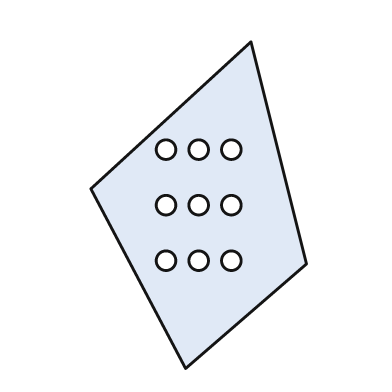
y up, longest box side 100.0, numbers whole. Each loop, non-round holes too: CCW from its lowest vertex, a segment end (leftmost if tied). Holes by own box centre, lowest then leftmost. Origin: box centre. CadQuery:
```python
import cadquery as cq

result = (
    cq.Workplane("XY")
    .moveTo(-4.0, -50.0)
    .lineTo(33.0, -18.0)
    .lineTo(16.0, 50.0)
    .lineTo(-33.0, 5.0)
    .close()
    .moveTo(-10.0, -17.0)
    .circle(3.0)
    .moveTo(0.0, -17.0)
    .circle(3.0)
    .moveTo(10.0, -17.0)
    .circle(3.0)
    .moveTo(-10.0, 0.0)
    .circle(3.0)
    .moveTo(0.0, 0.0)
    .circle(3.0)
    .moveTo(10.0, 0.0)
    .circle(3.0)
    .moveTo(-10.0, 17.0)
    .circle(3.0)
    .moveTo(0.0, 17.0)
    .circle(3.0)
    .moveTo(10.0, 17.0)
    .circle(3.0)
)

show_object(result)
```